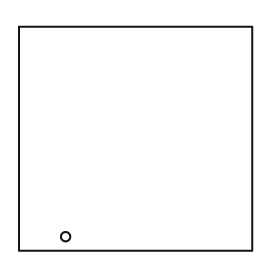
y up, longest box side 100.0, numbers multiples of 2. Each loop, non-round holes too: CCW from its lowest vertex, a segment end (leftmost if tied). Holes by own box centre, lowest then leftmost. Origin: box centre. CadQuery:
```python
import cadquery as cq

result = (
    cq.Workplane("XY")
    .moveTo(-50.0, -48.0)
    .lineTo(50.0, -48.0)
    .lineTo(50.0, 48.0)
    .lineTo(-50.0, 48.0)
    .close()
    .moveTo(-30.0, -42.0)
    .circle(2.0)
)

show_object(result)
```